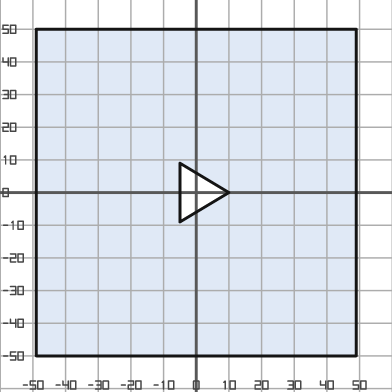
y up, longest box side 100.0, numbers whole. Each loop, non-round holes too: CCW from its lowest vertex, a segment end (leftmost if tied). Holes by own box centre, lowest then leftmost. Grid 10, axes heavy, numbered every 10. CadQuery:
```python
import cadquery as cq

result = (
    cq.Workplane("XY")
    .moveTo(-49.0, -50.0)
    .lineTo(49.0, -50.0)
    .lineTo(49.0, 50.0)
    .lineTo(-49.0, 50.0)
    .close()
    .moveTo(-5.0, -9.0)
    .lineTo(10.0, 0.0)
    .lineTo(-5.0, 9.0)
    .close()
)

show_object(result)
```